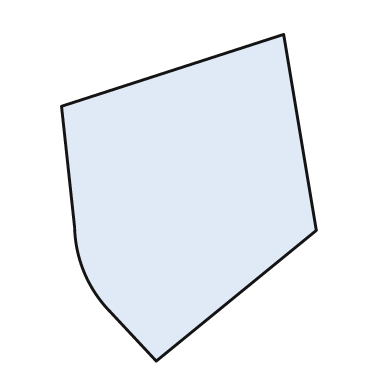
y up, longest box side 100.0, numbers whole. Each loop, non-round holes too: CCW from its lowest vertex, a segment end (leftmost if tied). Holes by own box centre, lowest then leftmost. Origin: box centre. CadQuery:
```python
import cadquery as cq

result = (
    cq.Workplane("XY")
    .moveTo(-10.0, -50.0)
    .lineTo(39.0, -10.0)
    .lineTo(29.0, 50.0)
    .lineTo(-39.0, 28.0)
    .lineTo(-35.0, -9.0)
    .threePointArc((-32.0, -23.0), (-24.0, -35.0))
    .close()
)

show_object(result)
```